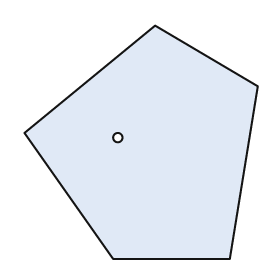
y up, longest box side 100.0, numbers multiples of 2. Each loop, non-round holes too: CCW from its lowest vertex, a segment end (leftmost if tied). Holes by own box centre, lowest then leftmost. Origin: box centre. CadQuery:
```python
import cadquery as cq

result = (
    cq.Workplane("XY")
    .moveTo(-12.0, -50.0)
    .lineTo(38.0, -50.0)
    .lineTo(50.0, 24.0)
    .lineTo(6.0, 50.0)
    .lineTo(-50.0, 4.0)
    .close()
    .moveTo(-10.0, 2.0)
    .circle(2.0)
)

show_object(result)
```